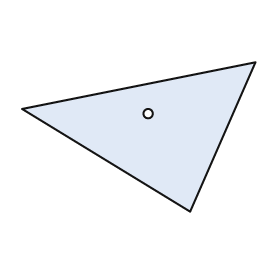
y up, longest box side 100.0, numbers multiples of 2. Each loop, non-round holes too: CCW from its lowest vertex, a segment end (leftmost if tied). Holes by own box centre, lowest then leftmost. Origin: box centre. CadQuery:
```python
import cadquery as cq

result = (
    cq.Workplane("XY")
    .moveTo(22.0, -32.0)
    .lineTo(50.0, 32.0)
    .lineTo(-50.0, 12.0)
    .close()
    .moveTo(4.0, 10.0)
    .circle(2.0)
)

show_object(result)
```